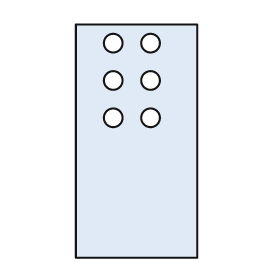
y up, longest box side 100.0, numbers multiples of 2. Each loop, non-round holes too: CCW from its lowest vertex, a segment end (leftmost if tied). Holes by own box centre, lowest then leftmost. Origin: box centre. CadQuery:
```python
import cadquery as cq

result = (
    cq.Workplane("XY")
    .moveTo(-26.0, -50.0)
    .lineTo(26.0, -50.0)
    .lineTo(26.0, 50.0)
    .lineTo(-26.0, 50.0)
    .close()
    .moveTo(-10.0, 10.0)
    .circle(4.0)
    .moveTo(6.0, 10.0)
    .circle(4.0)
    .moveTo(-10.0, 26.0)
    .circle(4.0)
    .moveTo(6.0, 26.0)
    .circle(4.0)
    .moveTo(-10.0, 42.0)
    .circle(4.0)
    .moveTo(6.0, 42.0)
    .circle(4.0)
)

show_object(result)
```